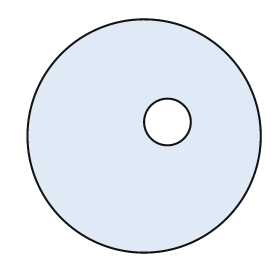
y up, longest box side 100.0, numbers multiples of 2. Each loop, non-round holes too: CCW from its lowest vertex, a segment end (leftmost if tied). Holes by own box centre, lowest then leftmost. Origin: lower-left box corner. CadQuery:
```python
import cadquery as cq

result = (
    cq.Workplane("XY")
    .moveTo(50.0, 50.0)
    .circle(50.0)
    .moveTo(60.0, 56.0)
    .circle(10.0)
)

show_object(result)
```